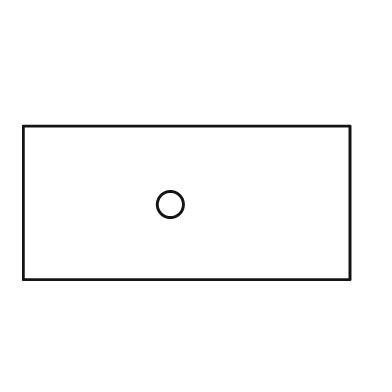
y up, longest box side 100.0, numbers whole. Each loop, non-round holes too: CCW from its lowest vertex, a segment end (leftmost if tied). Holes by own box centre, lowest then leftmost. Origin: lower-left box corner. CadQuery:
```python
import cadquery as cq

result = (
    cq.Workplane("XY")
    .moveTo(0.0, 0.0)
    .lineTo(100.0, 0.0)
    .lineTo(100.0, 47.0)
    .lineTo(0.0, 47.0)
    .close()
    .moveTo(45.0, 23.0)
    .circle(4.0)
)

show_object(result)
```